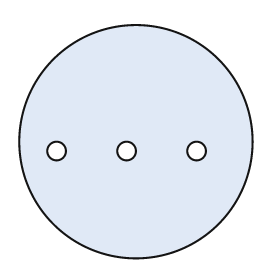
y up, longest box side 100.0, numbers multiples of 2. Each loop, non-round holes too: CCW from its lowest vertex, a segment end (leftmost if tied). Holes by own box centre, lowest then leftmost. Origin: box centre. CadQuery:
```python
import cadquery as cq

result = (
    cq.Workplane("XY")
    .moveTo(0.0, 0.0)
    .circle(50.0)
    .moveTo(-34.0, -4.0)
    .circle(4.0)
    .moveTo(-4.0, -4.0)
    .circle(4.0)
    .moveTo(26.0, -4.0)
    .circle(4.0)
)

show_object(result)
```